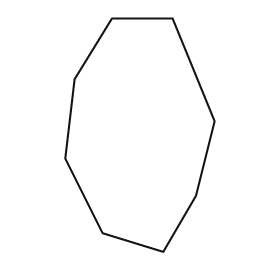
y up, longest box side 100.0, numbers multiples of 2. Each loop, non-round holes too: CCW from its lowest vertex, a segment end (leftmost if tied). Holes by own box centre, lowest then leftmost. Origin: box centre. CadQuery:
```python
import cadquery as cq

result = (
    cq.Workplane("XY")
    .moveTo(10.0, -50.0)
    .lineTo(24.0, -26.0)
    .lineTo(32.0, 6.0)
    .lineTo(14.0, 50.0)
    .lineTo(-12.0, 50.0)
    .lineTo(-28.0, 24.0)
    .lineTo(-32.0, -10.0)
    .lineTo(-16.0, -42.0)
    .close()
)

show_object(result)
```